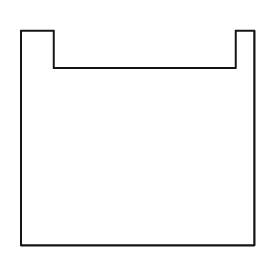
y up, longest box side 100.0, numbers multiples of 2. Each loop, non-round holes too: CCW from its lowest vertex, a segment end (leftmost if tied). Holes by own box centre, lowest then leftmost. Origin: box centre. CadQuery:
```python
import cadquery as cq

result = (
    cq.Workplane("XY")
    .moveTo(-50.0, -46.0)
    .lineTo(50.0, -46.0)
    .lineTo(50.0, 46.0)
    .lineTo(42.0, 46.0)
    .lineTo(42.0, 30.0)
    .lineTo(-36.0, 30.0)
    .lineTo(-36.0, 46.0)
    .lineTo(-50.0, 46.0)
    .close()
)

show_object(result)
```